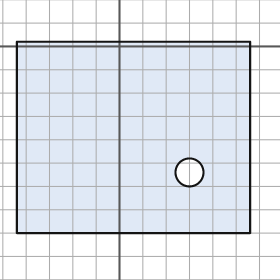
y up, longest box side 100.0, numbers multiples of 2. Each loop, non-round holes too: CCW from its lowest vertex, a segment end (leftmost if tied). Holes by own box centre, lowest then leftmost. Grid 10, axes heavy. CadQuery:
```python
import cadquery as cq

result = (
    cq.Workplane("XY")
    .moveTo(-44.0, -80.0)
    .lineTo(56.0, -80.0)
    .lineTo(56.0, 2.0)
    .lineTo(-44.0, 2.0)
    .close()
    .moveTo(30.0, -54.0)
    .circle(6.0)
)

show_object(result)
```